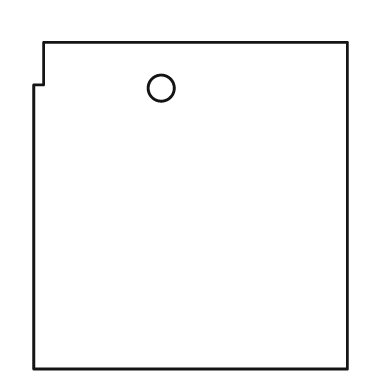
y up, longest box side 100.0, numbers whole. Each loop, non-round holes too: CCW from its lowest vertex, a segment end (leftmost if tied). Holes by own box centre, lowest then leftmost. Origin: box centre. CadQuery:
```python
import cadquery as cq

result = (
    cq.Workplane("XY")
    .moveTo(-48.0, -50.0)
    .lineTo(48.0, -50.0)
    .lineTo(48.0, 50.0)
    .lineTo(-45.0, 50.0)
    .lineTo(-45.0, 37.0)
    .lineTo(-48.0, 37.0)
    .close()
    .moveTo(-9.0, 36.0)
    .circle(4.0)
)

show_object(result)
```